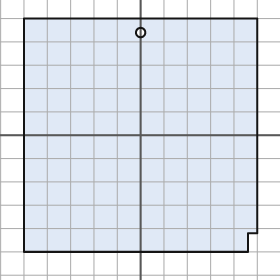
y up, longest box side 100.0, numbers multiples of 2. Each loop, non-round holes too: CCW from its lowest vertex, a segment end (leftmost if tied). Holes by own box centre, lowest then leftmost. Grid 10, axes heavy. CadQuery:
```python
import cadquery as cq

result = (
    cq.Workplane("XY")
    .moveTo(-50.0, -50.0)
    .lineTo(46.0, -50.0)
    .lineTo(46.0, -42.0)
    .lineTo(50.0, -42.0)
    .lineTo(50.0, 50.0)
    .lineTo(-50.0, 50.0)
    .close()
    .moveTo(0.0, 44.0)
    .circle(2.0)
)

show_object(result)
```